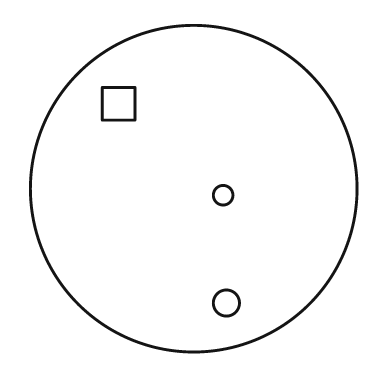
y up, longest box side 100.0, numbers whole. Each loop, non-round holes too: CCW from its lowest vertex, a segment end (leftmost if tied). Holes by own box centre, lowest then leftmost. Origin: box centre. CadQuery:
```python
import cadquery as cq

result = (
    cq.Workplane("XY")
    .moveTo(0.0, 0.0)
    .circle(50.0)
    .moveTo(10.0, -35.0)
    .circle(4.0)
    .moveTo(9.0, -2.0)
    .circle(3.0)
    .moveTo(-28.0, 21.0)
    .lineTo(-18.0, 21.0)
    .lineTo(-18.0, 31.0)
    .lineTo(-28.0, 31.0)
    .close()
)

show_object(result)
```